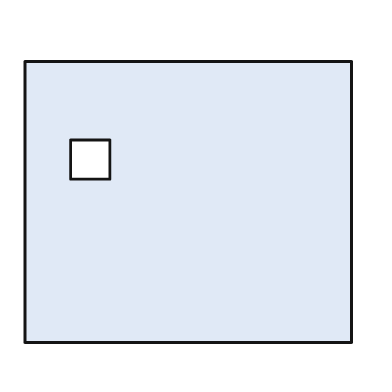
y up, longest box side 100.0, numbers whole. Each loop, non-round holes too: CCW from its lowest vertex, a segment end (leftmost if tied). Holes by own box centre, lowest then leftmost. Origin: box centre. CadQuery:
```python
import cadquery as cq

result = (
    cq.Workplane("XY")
    .moveTo(-50.0, -43.0)
    .lineTo(50.0, -43.0)
    .lineTo(50.0, 43.0)
    .lineTo(-50.0, 43.0)
    .close()
    .moveTo(-36.0, 7.0)
    .lineTo(-24.0, 7.0)
    .lineTo(-24.0, 19.0)
    .lineTo(-36.0, 19.0)
    .close()
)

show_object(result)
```